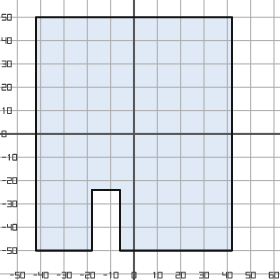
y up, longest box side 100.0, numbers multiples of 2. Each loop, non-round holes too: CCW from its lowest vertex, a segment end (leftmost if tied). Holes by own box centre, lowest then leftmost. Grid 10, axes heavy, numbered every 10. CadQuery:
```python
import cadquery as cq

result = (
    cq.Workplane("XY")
    .moveTo(-42.0, -50.0)
    .lineTo(-18.0, -50.0)
    .lineTo(-18.0, -24.0)
    .lineTo(-6.0, -24.0)
    .lineTo(-6.0, -50.0)
    .lineTo(42.0, -50.0)
    .lineTo(42.0, 50.0)
    .lineTo(-42.0, 50.0)
    .close()
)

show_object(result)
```